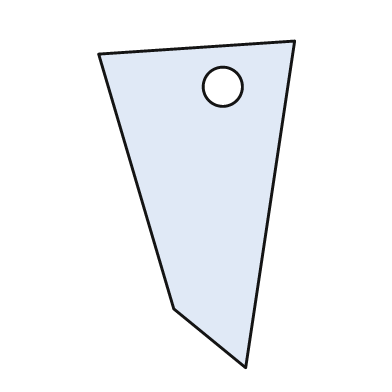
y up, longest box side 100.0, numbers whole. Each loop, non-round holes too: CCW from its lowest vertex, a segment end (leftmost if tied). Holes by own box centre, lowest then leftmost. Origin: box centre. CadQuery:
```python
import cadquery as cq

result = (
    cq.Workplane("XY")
    .moveTo(15.0, -50.0)
    .lineTo(30.0, 50.0)
    .lineTo(-30.0, 46.0)
    .lineTo(-7.0, -32.0)
    .close()
    .moveTo(8.0, 36.0)
    .circle(6.0)
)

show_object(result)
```